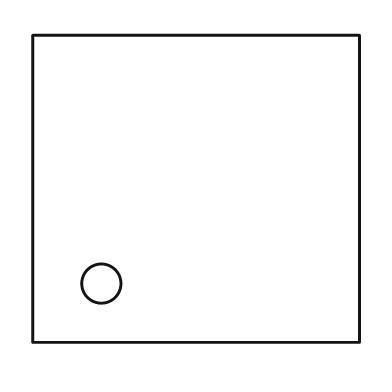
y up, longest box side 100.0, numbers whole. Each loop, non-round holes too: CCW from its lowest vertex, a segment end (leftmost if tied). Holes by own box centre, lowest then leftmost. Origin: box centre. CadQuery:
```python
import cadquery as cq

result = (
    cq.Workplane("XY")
    .moveTo(-50.0, -47.0)
    .lineTo(50.0, -47.0)
    .lineTo(50.0, 47.0)
    .lineTo(-50.0, 47.0)
    .close()
    .moveTo(-29.0, -29.0)
    .circle(6.0)
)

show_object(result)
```